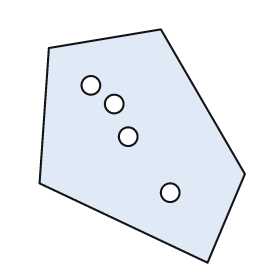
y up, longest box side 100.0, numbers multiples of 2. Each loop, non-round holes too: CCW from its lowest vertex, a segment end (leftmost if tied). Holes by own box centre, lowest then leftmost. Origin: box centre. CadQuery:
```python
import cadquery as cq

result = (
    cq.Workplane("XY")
    .moveTo(28.0, -50.0)
    .lineTo(44.0, -12.0)
    .lineTo(8.0, 50.0)
    .lineTo(-40.0, 42.0)
    .lineTo(-44.0, -16.0)
    .close()
    .moveTo(12.0, -20.0)
    .circle(4.0)
    .moveTo(-6.0, 4.0)
    .circle(4.0)
    .moveTo(-12.0, 18.0)
    .circle(4.0)
    .moveTo(-22.0, 26.0)
    .circle(4.0)
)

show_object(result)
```